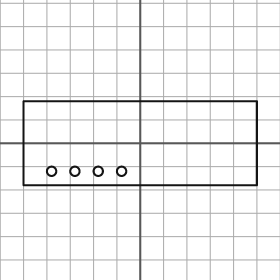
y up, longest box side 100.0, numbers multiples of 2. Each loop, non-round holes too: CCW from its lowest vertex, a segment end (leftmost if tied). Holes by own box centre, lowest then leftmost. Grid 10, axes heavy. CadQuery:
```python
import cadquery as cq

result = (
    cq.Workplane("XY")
    .moveTo(-50.0, -18.0)
    .lineTo(50.0, -18.0)
    .lineTo(50.0, 18.0)
    .lineTo(-50.0, 18.0)
    .close()
    .moveTo(-38.0, -12.0)
    .circle(2.0)
    .moveTo(-28.0, -12.0)
    .circle(2.0)
    .moveTo(-18.0, -12.0)
    .circle(2.0)
    .moveTo(-8.0, -12.0)
    .circle(2.0)
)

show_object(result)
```